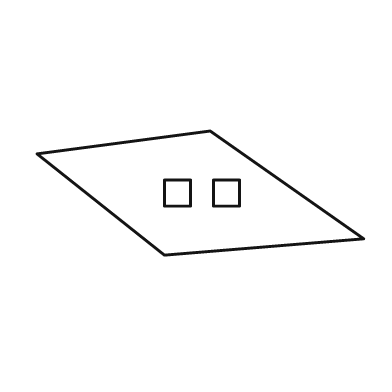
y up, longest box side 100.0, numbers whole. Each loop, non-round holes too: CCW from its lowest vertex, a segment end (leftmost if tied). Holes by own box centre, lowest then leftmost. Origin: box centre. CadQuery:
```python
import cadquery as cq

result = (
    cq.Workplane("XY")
    .moveTo(-11.0, -19.0)
    .lineTo(50.0, -14.0)
    .lineTo(3.0, 19.0)
    .lineTo(-50.0, 12.0)
    .close()
    .moveTo(-11.0, -4.0)
    .lineTo(-3.0, -4.0)
    .lineTo(-3.0, 4.0)
    .lineTo(-11.0, 4.0)
    .close()
    .moveTo(4.0, -4.0)
    .lineTo(12.0, -4.0)
    .lineTo(12.0, 4.0)
    .lineTo(4.0, 4.0)
    .close()
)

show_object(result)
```